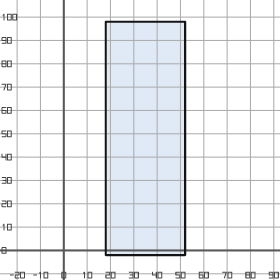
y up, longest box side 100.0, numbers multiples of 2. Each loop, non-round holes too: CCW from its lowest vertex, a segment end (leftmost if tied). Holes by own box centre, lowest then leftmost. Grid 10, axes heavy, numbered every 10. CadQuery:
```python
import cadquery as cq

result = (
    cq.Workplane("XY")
    .moveTo(18.0, -2.0)
    .lineTo(52.0, -2.0)
    .lineTo(52.0, 98.0)
    .lineTo(18.0, 98.0)
    .close()
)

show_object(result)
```